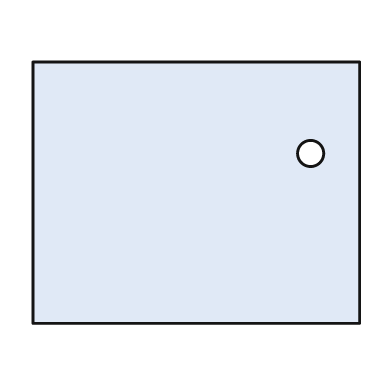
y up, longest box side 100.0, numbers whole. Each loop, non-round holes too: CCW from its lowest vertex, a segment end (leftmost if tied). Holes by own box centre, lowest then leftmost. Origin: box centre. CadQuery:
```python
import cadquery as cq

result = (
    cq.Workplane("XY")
    .moveTo(-50.0, -40.0)
    .lineTo(50.0, -40.0)
    .lineTo(50.0, 40.0)
    .lineTo(-50.0, 40.0)
    .close()
    .moveTo(35.0, 12.0)
    .circle(4.0)
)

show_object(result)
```